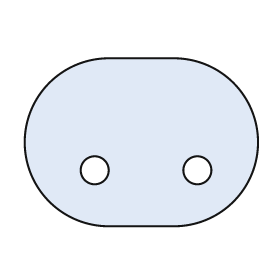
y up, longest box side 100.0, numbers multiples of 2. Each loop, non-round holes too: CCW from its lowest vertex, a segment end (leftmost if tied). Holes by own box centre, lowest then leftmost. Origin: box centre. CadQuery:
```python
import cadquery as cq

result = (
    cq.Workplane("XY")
    .moveTo(-14.0, -36.0)
    .lineTo(14.0, -36.0)
    .threePointArc((50.0, 0.0), (14.0, 36.0))
    .lineTo(-14.0, 36.0)
    .threePointArc((-50.0, 0.0), (-14.0, -36.0))
    .close()
    .moveTo(-20.0, -12.0)
    .circle(6.0)
    .moveTo(24.0, -12.0)
    .circle(6.0)
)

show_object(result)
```